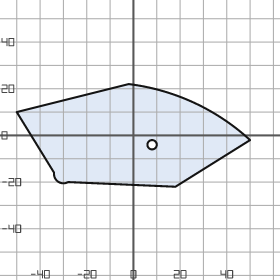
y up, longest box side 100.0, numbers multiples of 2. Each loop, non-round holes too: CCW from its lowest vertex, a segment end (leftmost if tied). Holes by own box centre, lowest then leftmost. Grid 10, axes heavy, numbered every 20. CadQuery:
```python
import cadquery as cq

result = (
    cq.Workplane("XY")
    .moveTo(18.0, -22.0)
    .lineTo(50.0, -2.0)
    .threePointArc((26.0, 14.0), (-2.0, 22.0))
    .lineTo(-50.0, 10.0)
    .lineTo(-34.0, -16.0)
    .threePointArc((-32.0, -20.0), (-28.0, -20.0))
    .close()
    .moveTo(8.0, -4.0)
    .circle(2.0)
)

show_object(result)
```